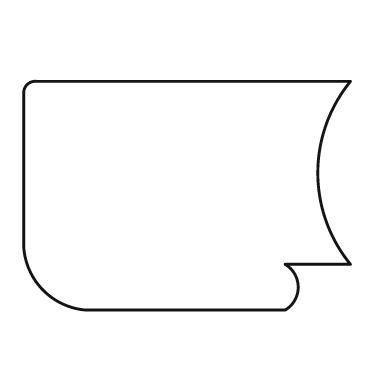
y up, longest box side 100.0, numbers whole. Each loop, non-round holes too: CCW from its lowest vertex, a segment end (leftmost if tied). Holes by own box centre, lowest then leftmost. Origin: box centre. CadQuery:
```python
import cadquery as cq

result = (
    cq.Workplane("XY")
    .moveTo(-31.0, -35.0)
    .lineTo(30.0, -35.0)
    .threePointArc((34.0, -28.0), (30.0, -21.0))
    .lineTo(50.0, -21.0)
    .threePointArc((40.0, 7.0), (50.0, 35.0))
    .lineTo(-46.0, 35.0)
    .threePointArc((-49.0, 34.0), (-50.0, 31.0))
    .lineTo(-50.0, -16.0)
    .threePointArc((-44.0, -29.0), (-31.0, -35.0))
    .close()
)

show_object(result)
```